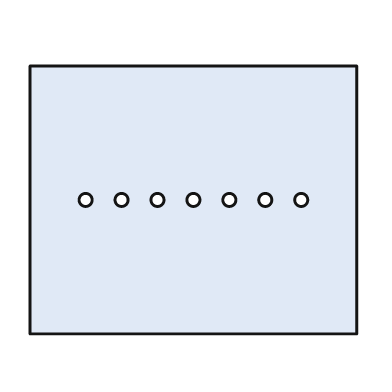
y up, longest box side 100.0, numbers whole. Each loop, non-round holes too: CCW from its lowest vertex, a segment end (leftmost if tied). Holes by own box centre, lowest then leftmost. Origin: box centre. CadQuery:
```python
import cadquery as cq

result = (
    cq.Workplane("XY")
    .moveTo(-50.0, -41.0)
    .lineTo(50.0, -41.0)
    .lineTo(50.0, 41.0)
    .lineTo(-50.0, 41.0)
    .close()
    .moveTo(-33.0, 0.0)
    .circle(2.0)
    .moveTo(-22.0, 0.0)
    .circle(2.0)
    .moveTo(-11.0, 0.0)
    .circle(2.0)
    .moveTo(0.0, 0.0)
    .circle(2.0)
    .moveTo(11.0, 0.0)
    .circle(2.0)
    .moveTo(22.0, 0.0)
    .circle(2.0)
    .moveTo(33.0, 0.0)
    .circle(2.0)
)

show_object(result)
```